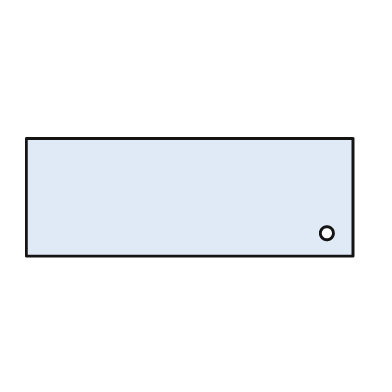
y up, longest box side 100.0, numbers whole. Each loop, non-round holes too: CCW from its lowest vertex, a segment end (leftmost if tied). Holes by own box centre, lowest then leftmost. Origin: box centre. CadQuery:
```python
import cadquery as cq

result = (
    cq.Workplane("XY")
    .moveTo(-50.0, -18.0)
    .lineTo(50.0, -18.0)
    .lineTo(50.0, 18.0)
    .lineTo(-50.0, 18.0)
    .close()
    .moveTo(42.0, -11.0)
    .circle(2.0)
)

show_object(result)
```